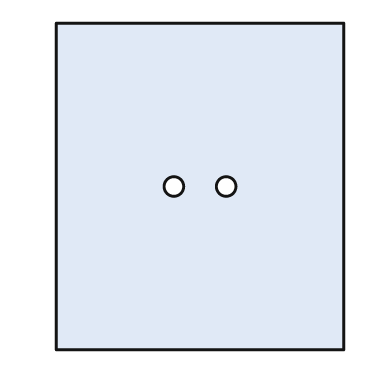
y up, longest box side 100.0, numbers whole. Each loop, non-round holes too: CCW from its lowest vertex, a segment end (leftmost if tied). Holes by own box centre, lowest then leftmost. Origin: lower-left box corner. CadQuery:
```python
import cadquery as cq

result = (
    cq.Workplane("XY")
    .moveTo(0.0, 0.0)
    .lineTo(88.0, 0.0)
    .lineTo(88.0, 100.0)
    .lineTo(0.0, 100.0)
    .close()
    .moveTo(36.0, 50.0)
    .circle(3.0)
    .moveTo(52.0, 50.0)
    .circle(3.0)
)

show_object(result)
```